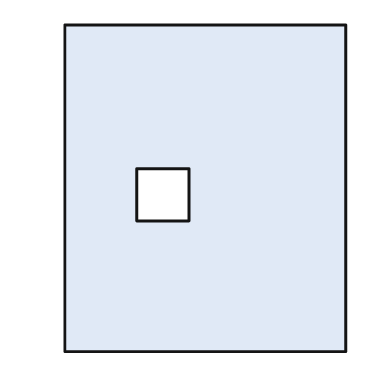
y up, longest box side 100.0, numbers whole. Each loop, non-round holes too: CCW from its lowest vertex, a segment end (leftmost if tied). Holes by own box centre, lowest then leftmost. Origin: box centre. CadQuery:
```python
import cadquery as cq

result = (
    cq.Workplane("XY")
    .moveTo(-43.0, -50.0)
    .lineTo(43.0, -50.0)
    .lineTo(43.0, 50.0)
    .lineTo(-43.0, 50.0)
    .close()
    .moveTo(-21.0, -10.0)
    .lineTo(-5.0, -10.0)
    .lineTo(-5.0, 6.0)
    .lineTo(-21.0, 6.0)
    .close()
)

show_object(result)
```